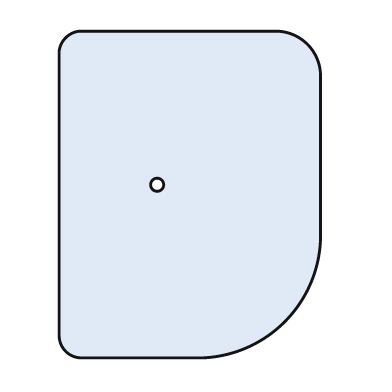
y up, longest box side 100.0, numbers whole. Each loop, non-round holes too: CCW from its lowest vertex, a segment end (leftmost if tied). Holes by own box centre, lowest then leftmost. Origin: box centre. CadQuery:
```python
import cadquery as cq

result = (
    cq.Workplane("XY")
    .moveTo(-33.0, -50.0)
    .lineTo(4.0, -50.0)
    .threePointArc((29.0, -39.0), (40.0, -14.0))
    .lineTo(40.0, 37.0)
    .threePointArc((36.0, 46.0), (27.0, 50.0))
    .lineTo(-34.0, 50.0)
    .threePointArc((-38.0, 48.0), (-40.0, 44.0))
    .lineTo(-40.0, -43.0)
    .threePointArc((-38.0, -48.0), (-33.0, -50.0))
    .close()
    .moveTo(-10.0, 3.0)
    .circle(2.0)
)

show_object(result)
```